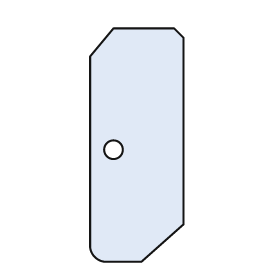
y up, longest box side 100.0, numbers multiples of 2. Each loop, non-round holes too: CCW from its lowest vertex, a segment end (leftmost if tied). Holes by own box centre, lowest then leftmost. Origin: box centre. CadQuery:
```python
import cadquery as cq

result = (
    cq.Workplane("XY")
    .moveTo(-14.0, -50.0)
    .lineTo(2.0, -50.0)
    .lineTo(20.0, -34.0)
    .lineTo(20.0, 46.0)
    .lineTo(16.0, 50.0)
    .lineTo(-10.0, 50.0)
    .lineTo(-20.0, 38.0)
    .lineTo(-20.0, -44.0)
    .threePointArc((-18.0, -48.0), (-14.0, -50.0))
    .close()
    .moveTo(-10.0, -2.0)
    .circle(4.0)
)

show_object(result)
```